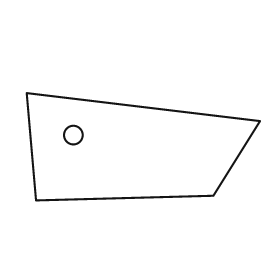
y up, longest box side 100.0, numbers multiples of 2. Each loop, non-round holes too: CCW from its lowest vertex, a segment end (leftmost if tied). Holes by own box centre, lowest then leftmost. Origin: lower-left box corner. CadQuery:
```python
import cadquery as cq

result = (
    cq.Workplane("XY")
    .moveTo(4.0, 0.0)
    .lineTo(80.0, 2.0)
    .lineTo(100.0, 34.0)
    .lineTo(0.0, 46.0)
    .close()
    .moveTo(20.0, 28.0)
    .circle(4.0)
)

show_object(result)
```